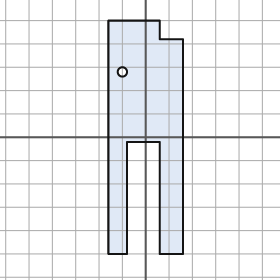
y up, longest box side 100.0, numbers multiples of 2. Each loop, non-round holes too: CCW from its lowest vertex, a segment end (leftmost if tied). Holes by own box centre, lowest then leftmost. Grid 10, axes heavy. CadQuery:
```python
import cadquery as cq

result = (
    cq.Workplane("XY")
    .moveTo(-16.0, -50.0)
    .lineTo(-8.0, -50.0)
    .lineTo(-8.0, -2.0)
    .lineTo(6.0, -2.0)
    .lineTo(6.0, -50.0)
    .lineTo(16.0, -50.0)
    .lineTo(16.0, 42.0)
    .lineTo(6.0, 42.0)
    .lineTo(6.0, 50.0)
    .lineTo(-16.0, 50.0)
    .close()
    .moveTo(-10.0, 28.0)
    .circle(2.0)
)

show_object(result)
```